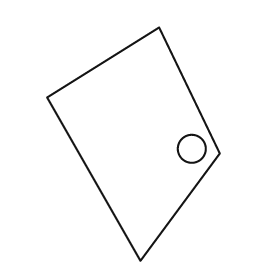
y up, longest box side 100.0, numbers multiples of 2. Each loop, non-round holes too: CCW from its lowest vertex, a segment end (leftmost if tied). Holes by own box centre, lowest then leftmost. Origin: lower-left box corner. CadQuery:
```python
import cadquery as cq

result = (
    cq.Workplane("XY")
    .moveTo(40.0, 0.0)
    .lineTo(74.0, 46.0)
    .lineTo(48.0, 100.0)
    .lineTo(0.0, 70.0)
    .close()
    .moveTo(62.0, 48.0)
    .circle(6.0)
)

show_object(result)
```